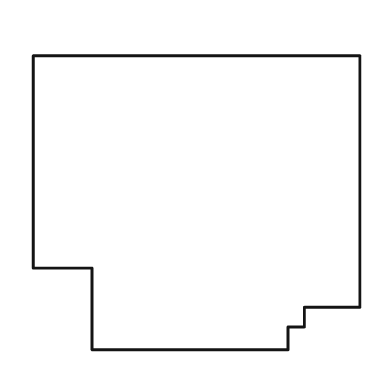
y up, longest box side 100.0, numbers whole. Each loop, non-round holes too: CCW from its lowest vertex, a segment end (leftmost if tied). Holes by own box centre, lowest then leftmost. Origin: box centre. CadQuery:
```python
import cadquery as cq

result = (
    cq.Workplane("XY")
    .moveTo(-32.0, -45.0)
    .lineTo(28.0, -45.0)
    .lineTo(28.0, -38.0)
    .lineTo(33.0, -38.0)
    .lineTo(33.0, -32.0)
    .lineTo(50.0, -32.0)
    .lineTo(50.0, 45.0)
    .lineTo(-50.0, 45.0)
    .lineTo(-50.0, -20.0)
    .lineTo(-32.0, -20.0)
    .close()
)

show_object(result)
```